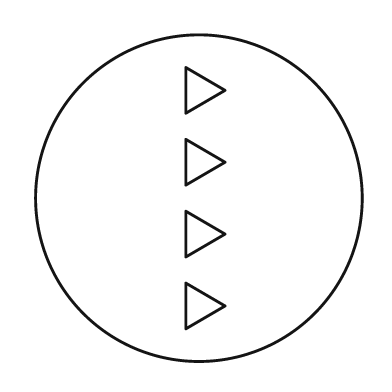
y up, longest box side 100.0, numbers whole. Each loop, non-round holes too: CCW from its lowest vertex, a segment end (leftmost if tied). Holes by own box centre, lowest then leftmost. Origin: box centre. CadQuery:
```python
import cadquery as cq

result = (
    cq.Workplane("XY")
    .moveTo(0.0, 0.0)
    .circle(50.0)
    .moveTo(-4.0, -40.0)
    .lineTo(8.0, -33.0)
    .lineTo(-4.0, -26.0)
    .close()
    .moveTo(-4.0, -18.0)
    .lineTo(8.0, -11.0)
    .lineTo(-4.0, -4.0)
    .close()
    .moveTo(-4.0, 4.0)
    .lineTo(8.0, 11.0)
    .lineTo(-4.0, 18.0)
    .close()
    .moveTo(-4.0, 26.0)
    .lineTo(8.0, 33.0)
    .lineTo(-4.0, 40.0)
    .close()
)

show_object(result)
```